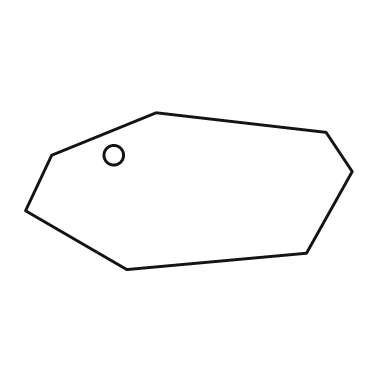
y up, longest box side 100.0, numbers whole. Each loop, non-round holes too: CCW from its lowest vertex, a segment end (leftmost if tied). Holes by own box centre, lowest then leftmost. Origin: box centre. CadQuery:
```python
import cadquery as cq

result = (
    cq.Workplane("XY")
    .moveTo(-19.0, -24.0)
    .lineTo(36.0, -19.0)
    .lineTo(50.0, 6.0)
    .lineTo(42.0, 18.0)
    .lineTo(-10.0, 24.0)
    .lineTo(-42.0, 11.0)
    .lineTo(-50.0, -6.0)
    .close()
    .moveTo(-23.0, 11.0)
    .circle(3.0)
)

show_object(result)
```